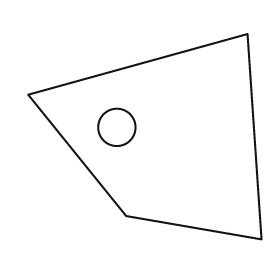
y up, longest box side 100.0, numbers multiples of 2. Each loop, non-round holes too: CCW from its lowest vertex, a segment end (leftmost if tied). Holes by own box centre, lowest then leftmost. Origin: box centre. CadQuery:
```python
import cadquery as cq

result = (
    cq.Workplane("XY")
    .moveTo(50.0, -44.0)
    .lineTo(44.0, 44.0)
    .lineTo(-50.0, 18.0)
    .lineTo(-8.0, -34.0)
    .close()
    .moveTo(-12.0, 4.0)
    .circle(8.0)
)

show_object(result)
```